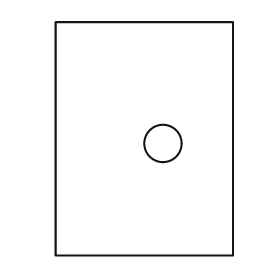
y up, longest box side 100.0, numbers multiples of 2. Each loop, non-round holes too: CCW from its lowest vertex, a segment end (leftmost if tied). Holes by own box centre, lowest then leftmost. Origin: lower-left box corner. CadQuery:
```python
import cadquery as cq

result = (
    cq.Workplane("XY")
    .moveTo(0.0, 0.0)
    .lineTo(76.0, 0.0)
    .lineTo(76.0, 100.0)
    .lineTo(0.0, 100.0)
    .close()
    .moveTo(46.0, 48.0)
    .circle(8.0)
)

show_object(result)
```